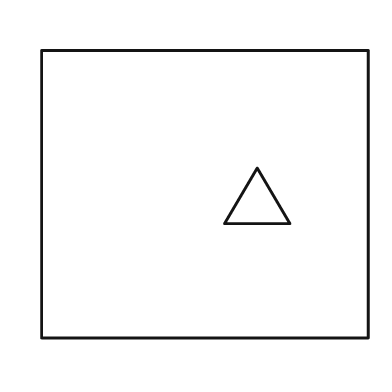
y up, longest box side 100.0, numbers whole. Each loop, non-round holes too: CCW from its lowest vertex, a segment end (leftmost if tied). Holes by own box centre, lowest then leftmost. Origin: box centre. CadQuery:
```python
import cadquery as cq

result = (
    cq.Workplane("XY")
    .moveTo(-50.0, -44.0)
    .lineTo(50.0, -44.0)
    .lineTo(50.0, 44.0)
    .lineTo(-50.0, 44.0)
    .close()
    .moveTo(6.0, -9.0)
    .lineTo(26.0, -9.0)
    .lineTo(16.0, 8.0)
    .close()
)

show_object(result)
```